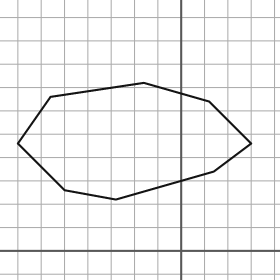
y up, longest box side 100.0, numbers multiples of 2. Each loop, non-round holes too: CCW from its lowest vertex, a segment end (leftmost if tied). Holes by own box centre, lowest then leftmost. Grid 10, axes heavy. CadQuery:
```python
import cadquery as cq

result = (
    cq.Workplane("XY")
    .moveTo(-28.0, 22.0)
    .lineTo(14.0, 34.0)
    .lineTo(30.0, 46.0)
    .lineTo(12.0, 64.0)
    .lineTo(-16.0, 72.0)
    .lineTo(-56.0, 66.0)
    .lineTo(-70.0, 46.0)
    .lineTo(-50.0, 26.0)
    .close()
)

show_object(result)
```